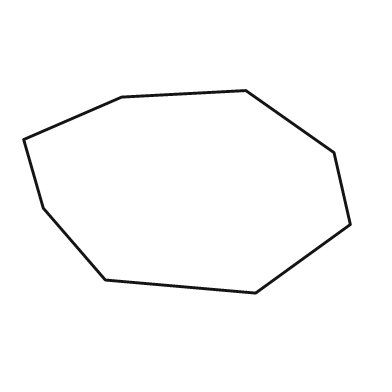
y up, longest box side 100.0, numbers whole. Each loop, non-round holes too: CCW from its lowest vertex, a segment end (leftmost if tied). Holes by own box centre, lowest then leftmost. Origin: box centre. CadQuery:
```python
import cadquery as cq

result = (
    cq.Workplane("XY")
    .moveTo(21.0, -31.0)
    .lineTo(50.0, -10.0)
    .lineTo(45.0, 12.0)
    .lineTo(18.0, 31.0)
    .lineTo(-20.0, 29.0)
    .lineTo(-50.0, 16.0)
    .lineTo(-44.0, -5.0)
    .lineTo(-25.0, -27.0)
    .close()
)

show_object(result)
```